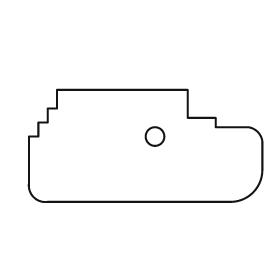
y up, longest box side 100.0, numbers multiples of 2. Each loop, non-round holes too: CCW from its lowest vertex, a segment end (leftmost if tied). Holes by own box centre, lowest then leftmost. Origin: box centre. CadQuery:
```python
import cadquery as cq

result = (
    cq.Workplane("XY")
    .moveTo(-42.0, -24.0)
    .lineTo(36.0, -24.0)
    .threePointArc((46.0, -20.0), (50.0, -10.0))
    .lineTo(50.0, 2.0)
    .threePointArc((48.0, 6.0), (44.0, 8.0))
    .lineTo(30.0, 8.0)
    .lineTo(30.0, 12.0)
    .lineTo(18.0, 12.0)
    .lineTo(18.0, 24.0)
    .lineTo(-38.0, 24.0)
    .lineTo(-38.0, 16.0)
    .lineTo(-42.0, 16.0)
    .lineTo(-42.0, 10.0)
    .lineTo(-46.0, 10.0)
    .lineTo(-46.0, 4.0)
    .lineTo(-50.0, 4.0)
    .lineTo(-50.0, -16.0)
    .threePointArc((-48.0, -22.0), (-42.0, -24.0))
    .close()
    .moveTo(4.0, 4.0)
    .circle(4.0)
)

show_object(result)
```